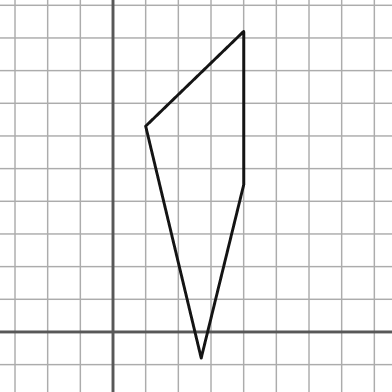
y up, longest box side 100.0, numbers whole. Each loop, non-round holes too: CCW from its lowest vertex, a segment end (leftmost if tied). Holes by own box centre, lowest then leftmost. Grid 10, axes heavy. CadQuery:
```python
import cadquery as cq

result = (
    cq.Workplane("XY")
    .moveTo(27.0, -8.0)
    .lineTo(40.0, 45.0)
    .lineTo(40.0, 92.0)
    .lineTo(10.0, 63.0)
    .close()
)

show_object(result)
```